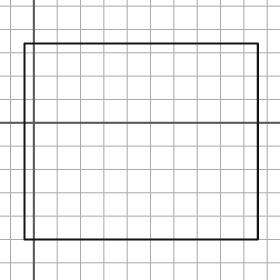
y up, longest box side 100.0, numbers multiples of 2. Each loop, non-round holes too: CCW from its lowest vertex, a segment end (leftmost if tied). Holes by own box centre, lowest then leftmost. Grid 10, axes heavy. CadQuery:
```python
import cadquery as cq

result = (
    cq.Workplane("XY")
    .moveTo(-4.0, -50.0)
    .lineTo(96.0, -50.0)
    .lineTo(96.0, 34.0)
    .lineTo(-4.0, 34.0)
    .close()
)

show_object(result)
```